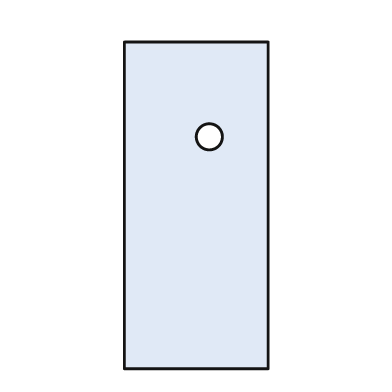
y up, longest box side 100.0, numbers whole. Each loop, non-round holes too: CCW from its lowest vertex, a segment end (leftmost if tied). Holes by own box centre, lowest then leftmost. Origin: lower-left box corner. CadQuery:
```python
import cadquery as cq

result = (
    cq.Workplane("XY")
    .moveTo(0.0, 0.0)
    .lineTo(44.0, 0.0)
    .lineTo(44.0, 100.0)
    .lineTo(0.0, 100.0)
    .close()
    .moveTo(26.0, 71.0)
    .circle(4.0)
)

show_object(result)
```